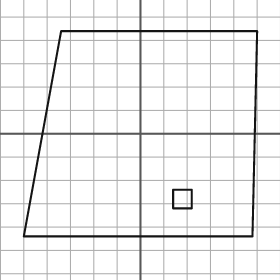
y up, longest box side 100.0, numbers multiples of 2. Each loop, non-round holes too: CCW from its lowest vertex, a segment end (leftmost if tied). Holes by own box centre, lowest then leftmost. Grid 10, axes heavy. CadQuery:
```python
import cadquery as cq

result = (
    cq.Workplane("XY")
    .moveTo(-50.0, -44.0)
    .lineTo(48.0, -44.0)
    .lineTo(50.0, 44.0)
    .lineTo(-34.0, 44.0)
    .close()
    .moveTo(14.0, -32.0)
    .lineTo(22.0, -32.0)
    .lineTo(22.0, -24.0)
    .lineTo(14.0, -24.0)
    .close()
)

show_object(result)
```